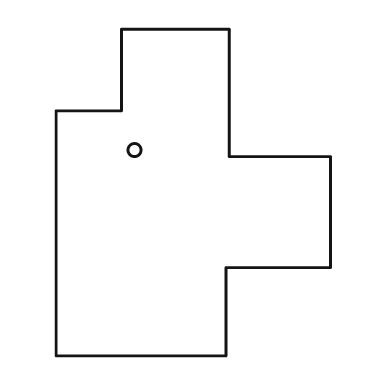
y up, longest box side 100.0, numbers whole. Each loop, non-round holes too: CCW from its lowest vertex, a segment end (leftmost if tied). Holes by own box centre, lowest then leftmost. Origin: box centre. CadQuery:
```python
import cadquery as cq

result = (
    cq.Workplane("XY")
    .moveTo(-42.0, -50.0)
    .lineTo(10.0, -50.0)
    .lineTo(10.0, -23.0)
    .lineTo(42.0, -23.0)
    .lineTo(42.0, 11.0)
    .lineTo(11.0, 11.0)
    .lineTo(11.0, 50.0)
    .lineTo(-22.0, 50.0)
    .lineTo(-22.0, 25.0)
    .lineTo(-42.0, 25.0)
    .close()
    .moveTo(-18.0, 13.0)
    .circle(2.0)
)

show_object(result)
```